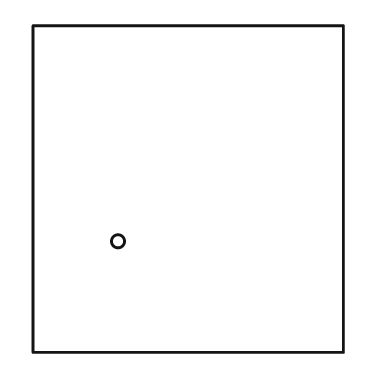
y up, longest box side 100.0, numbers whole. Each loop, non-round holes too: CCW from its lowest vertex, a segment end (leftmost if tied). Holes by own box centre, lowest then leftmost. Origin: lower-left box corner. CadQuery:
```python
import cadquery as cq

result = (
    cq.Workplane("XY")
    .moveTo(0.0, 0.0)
    .lineTo(95.0, 0.0)
    .lineTo(95.0, 100.0)
    .lineTo(0.0, 100.0)
    .close()
    .moveTo(26.0, 34.0)
    .circle(2.0)
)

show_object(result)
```